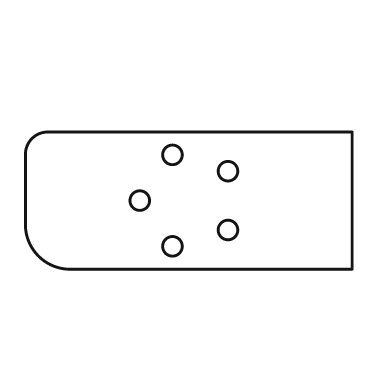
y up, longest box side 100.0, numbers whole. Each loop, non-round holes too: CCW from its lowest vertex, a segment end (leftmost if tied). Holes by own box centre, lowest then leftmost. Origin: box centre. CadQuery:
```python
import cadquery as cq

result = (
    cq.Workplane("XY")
    .moveTo(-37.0, -21.0)
    .lineTo(50.0, -21.0)
    .lineTo(50.0, 21.0)
    .lineTo(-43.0, 21.0)
    .threePointArc((-48.0, 19.0), (-50.0, 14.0))
    .lineTo(-50.0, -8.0)
    .threePointArc((-46.0, -17.0), (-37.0, -21.0))
    .close()
    .moveTo(-5.0, -14.0)
    .circle(3.0)
    .moveTo(12.0, -9.0)
    .circle(3.0)
    .moveTo(-15.0, 0.0)
    .circle(3.0)
    .moveTo(12.0, 9.0)
    .circle(3.0)
    .moveTo(-5.0, 14.0)
    .circle(3.0)
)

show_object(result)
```